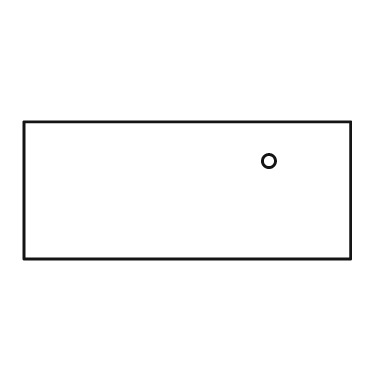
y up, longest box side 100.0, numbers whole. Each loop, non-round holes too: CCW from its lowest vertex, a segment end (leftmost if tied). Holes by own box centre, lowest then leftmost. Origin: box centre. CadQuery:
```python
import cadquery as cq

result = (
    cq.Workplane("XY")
    .moveTo(-50.0, -21.0)
    .lineTo(50.0, -21.0)
    .lineTo(50.0, 21.0)
    .lineTo(-50.0, 21.0)
    .close()
    .moveTo(25.0, 9.0)
    .circle(2.0)
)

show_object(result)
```